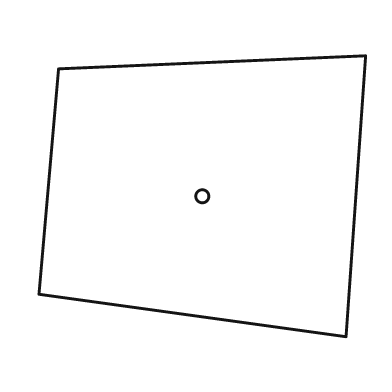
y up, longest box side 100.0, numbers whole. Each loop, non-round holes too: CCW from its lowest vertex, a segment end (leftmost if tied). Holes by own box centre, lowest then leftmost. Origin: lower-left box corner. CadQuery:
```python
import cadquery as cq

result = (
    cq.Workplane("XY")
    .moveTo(94.0, 0.0)
    .lineTo(100.0, 86.0)
    .lineTo(6.0, 82.0)
    .lineTo(0.0, 13.0)
    .close()
    .moveTo(50.0, 43.0)
    .circle(2.0)
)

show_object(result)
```